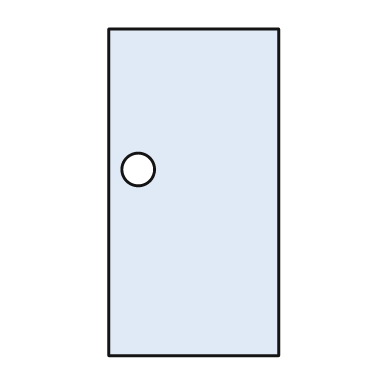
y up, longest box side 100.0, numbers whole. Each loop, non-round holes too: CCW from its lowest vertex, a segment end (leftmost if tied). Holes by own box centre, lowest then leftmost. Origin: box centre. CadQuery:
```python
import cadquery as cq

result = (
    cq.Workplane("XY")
    .moveTo(-26.0, -50.0)
    .lineTo(26.0, -50.0)
    .lineTo(26.0, 50.0)
    .lineTo(-26.0, 50.0)
    .close()
    .moveTo(-17.0, 7.0)
    .circle(5.0)
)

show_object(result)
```